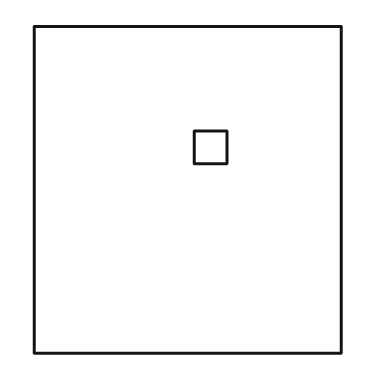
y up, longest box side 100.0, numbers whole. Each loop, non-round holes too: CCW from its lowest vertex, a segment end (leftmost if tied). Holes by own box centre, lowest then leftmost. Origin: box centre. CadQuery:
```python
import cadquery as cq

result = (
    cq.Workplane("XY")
    .moveTo(-47.0, -50.0)
    .lineTo(47.0, -50.0)
    .lineTo(47.0, 50.0)
    .lineTo(-47.0, 50.0)
    .close()
    .moveTo(2.0, 8.0)
    .lineTo(12.0, 8.0)
    .lineTo(12.0, 18.0)
    .lineTo(2.0, 18.0)
    .close()
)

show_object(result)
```